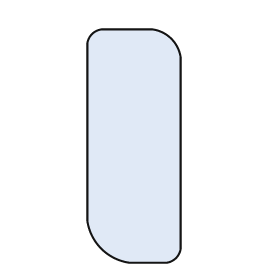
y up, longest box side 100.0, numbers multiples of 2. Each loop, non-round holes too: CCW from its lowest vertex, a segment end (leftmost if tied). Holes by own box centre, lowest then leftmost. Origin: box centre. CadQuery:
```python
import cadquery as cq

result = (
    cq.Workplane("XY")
    .moveTo(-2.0, -50.0)
    .lineTo(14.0, -50.0)
    .threePointArc((18.0, -48.0), (20.0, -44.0))
    .lineTo(20.0, 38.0)
    .threePointArc((16.0, 46.0), (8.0, 50.0))
    .lineTo(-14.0, 50.0)
    .threePointArc((-18.0, 48.0), (-20.0, 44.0))
    .lineTo(-20.0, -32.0)
    .threePointArc((-14.0, -44.0), (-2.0, -50.0))
    .close()
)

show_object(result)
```